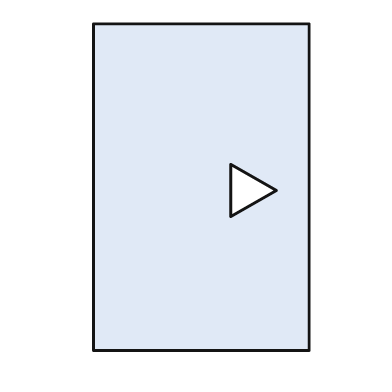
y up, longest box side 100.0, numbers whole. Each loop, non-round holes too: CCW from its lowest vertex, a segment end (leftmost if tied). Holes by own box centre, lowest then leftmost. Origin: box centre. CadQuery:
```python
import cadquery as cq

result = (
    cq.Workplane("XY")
    .moveTo(-33.0, -50.0)
    .lineTo(33.0, -50.0)
    .lineTo(33.0, 50.0)
    .lineTo(-33.0, 50.0)
    .close()
    .moveTo(9.0, -9.0)
    .lineTo(23.0, -1.0)
    .lineTo(9.0, 7.0)
    .close()
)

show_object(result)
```